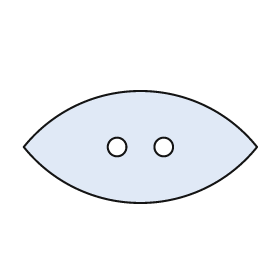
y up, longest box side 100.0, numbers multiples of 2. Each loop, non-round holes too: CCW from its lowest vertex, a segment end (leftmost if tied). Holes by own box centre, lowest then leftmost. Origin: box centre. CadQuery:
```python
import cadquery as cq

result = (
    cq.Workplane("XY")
    .moveTo(-50.0, 0.0)
    .threePointArc((0.0, -24.0), (50.0, 0.0))
    .threePointArc((0.0, 24.0), (-50.0, 0.0))
    .close()
    .moveTo(-10.0, 0.0)
    .circle(4.0)
    .moveTo(10.0, 0.0)
    .circle(4.0)
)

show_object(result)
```